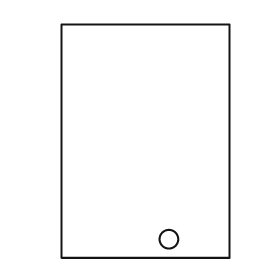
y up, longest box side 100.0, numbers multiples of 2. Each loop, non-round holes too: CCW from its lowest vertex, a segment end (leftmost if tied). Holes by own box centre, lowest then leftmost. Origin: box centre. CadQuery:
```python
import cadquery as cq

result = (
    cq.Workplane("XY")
    .moveTo(-36.0, -50.0)
    .lineTo(36.0, -50.0)
    .lineTo(36.0, 50.0)
    .lineTo(-36.0, 50.0)
    .close()
    .moveTo(10.0, -42.0)
    .circle(4.0)
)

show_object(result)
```